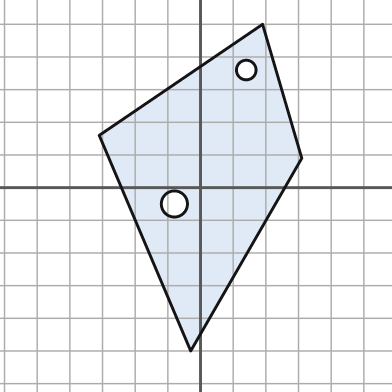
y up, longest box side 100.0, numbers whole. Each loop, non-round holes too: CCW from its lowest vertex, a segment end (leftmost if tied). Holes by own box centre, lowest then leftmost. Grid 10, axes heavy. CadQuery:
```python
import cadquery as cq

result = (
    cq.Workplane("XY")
    .moveTo(-3.0, -50.0)
    .lineTo(31.0, 9.0)
    .lineTo(19.0, 50.0)
    .lineTo(-31.0, 16.0)
    .close()
    .moveTo(-8.0, -5.0)
    .circle(4.0)
    .moveTo(14.0, 36.0)
    .circle(3.0)
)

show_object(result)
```